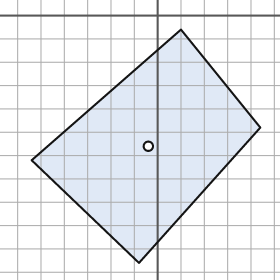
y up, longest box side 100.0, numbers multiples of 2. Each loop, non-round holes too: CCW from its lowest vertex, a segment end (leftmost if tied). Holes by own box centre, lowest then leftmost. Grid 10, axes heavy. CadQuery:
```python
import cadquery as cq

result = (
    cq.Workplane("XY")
    .moveTo(-8.0, -106.0)
    .lineTo(44.0, -48.0)
    .lineTo(10.0, -6.0)
    .lineTo(-54.0, -62.0)
    .close()
    .moveTo(-4.0, -56.0)
    .circle(2.0)
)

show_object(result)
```